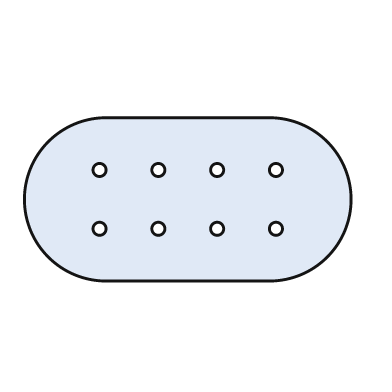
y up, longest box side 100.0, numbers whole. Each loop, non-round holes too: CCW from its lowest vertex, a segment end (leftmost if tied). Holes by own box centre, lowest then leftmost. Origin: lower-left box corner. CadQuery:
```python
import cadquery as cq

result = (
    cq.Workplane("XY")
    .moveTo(25.0, 0.0)
    .lineTo(75.0, 0.0)
    .threePointArc((100.0, 25.0), (75.0, 50.0))
    .lineTo(25.0, 50.0)
    .threePointArc((0.0, 25.0), (25.0, 0.0))
    .close()
    .moveTo(23.0, 16.0)
    .circle(2.0)
    .moveTo(41.0, 16.0)
    .circle(2.0)
    .moveTo(59.0, 16.0)
    .circle(2.0)
    .moveTo(77.0, 16.0)
    .circle(2.0)
    .moveTo(23.0, 34.0)
    .circle(2.0)
    .moveTo(41.0, 34.0)
    .circle(2.0)
    .moveTo(59.0, 34.0)
    .circle(2.0)
    .moveTo(77.0, 34.0)
    .circle(2.0)
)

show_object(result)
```